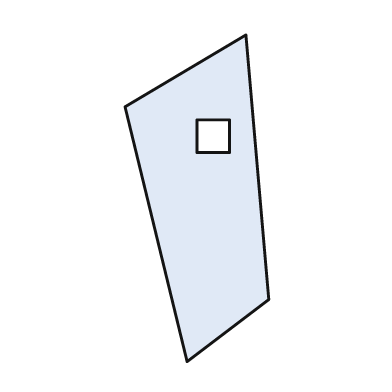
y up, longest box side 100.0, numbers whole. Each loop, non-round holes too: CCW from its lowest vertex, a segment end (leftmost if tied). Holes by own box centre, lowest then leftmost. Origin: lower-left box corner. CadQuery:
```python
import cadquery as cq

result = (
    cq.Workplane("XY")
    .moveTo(19.0, 0.0)
    .lineTo(44.0, 19.0)
    .lineTo(37.0, 100.0)
    .lineTo(0.0, 78.0)
    .close()
    .moveTo(22.0, 64.0)
    .lineTo(32.0, 64.0)
    .lineTo(32.0, 74.0)
    .lineTo(22.0, 74.0)
    .close()
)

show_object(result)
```